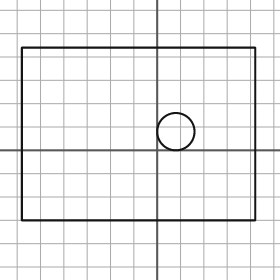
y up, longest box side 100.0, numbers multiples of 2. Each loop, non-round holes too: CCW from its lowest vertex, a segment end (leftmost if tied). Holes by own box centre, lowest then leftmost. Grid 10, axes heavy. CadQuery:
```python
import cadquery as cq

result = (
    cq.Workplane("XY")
    .moveTo(-58.0, -30.0)
    .lineTo(42.0, -30.0)
    .lineTo(42.0, 44.0)
    .lineTo(-58.0, 44.0)
    .close()
    .moveTo(8.0, 8.0)
    .circle(8.0)
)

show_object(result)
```